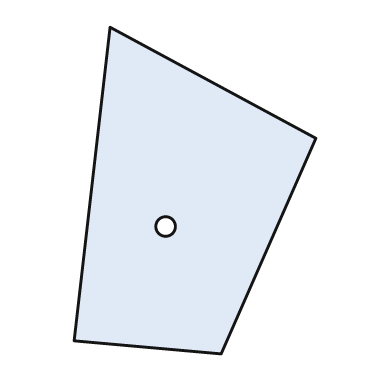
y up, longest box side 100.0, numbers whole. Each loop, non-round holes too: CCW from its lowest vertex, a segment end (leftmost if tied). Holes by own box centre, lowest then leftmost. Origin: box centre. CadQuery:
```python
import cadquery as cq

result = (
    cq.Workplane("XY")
    .moveTo(8.0, -50.0)
    .lineTo(37.0, 16.0)
    .lineTo(-26.0, 50.0)
    .lineTo(-37.0, -46.0)
    .close()
    .moveTo(-9.0, -11.0)
    .circle(3.0)
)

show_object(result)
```